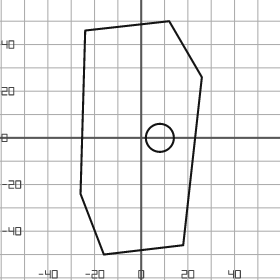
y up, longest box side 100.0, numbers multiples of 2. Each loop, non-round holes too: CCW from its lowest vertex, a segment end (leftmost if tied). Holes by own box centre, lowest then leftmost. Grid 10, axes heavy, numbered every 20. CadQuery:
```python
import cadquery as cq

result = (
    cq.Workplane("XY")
    .moveTo(-16.0, -50.0)
    .lineTo(18.0, -46.0)
    .lineTo(26.0, 26.0)
    .lineTo(12.0, 50.0)
    .lineTo(-24.0, 46.0)
    .lineTo(-26.0, -24.0)
    .close()
    .moveTo(8.0, 0.0)
    .circle(6.0)
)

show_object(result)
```